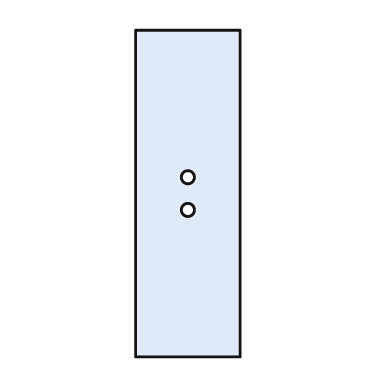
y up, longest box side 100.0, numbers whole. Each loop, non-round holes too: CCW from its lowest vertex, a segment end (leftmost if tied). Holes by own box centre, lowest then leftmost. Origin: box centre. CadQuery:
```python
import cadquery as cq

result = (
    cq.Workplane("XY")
    .moveTo(-16.0, -50.0)
    .lineTo(16.0, -50.0)
    .lineTo(16.0, 50.0)
    .lineTo(-16.0, 50.0)
    .close()
    .moveTo(0.0, -5.0)
    .circle(2.0)
    .moveTo(0.0, 5.0)
    .circle(2.0)
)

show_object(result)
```